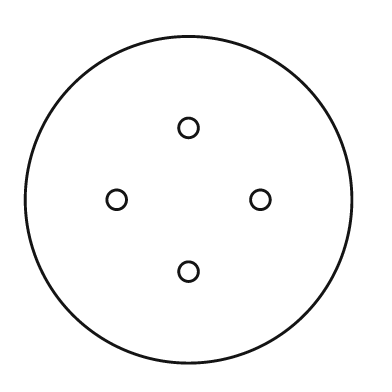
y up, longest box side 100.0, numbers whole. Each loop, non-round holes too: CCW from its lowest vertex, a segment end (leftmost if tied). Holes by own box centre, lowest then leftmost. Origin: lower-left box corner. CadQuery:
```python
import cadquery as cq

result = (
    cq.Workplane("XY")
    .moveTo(50.0, 50.0)
    .circle(50.0)
    .moveTo(50.0, 28.0)
    .circle(3.0)
    .moveTo(28.0, 50.0)
    .circle(3.0)
    .moveTo(72.0, 50.0)
    .circle(3.0)
    .moveTo(50.0, 72.0)
    .circle(3.0)
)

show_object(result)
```